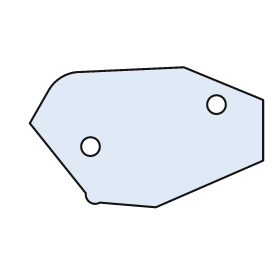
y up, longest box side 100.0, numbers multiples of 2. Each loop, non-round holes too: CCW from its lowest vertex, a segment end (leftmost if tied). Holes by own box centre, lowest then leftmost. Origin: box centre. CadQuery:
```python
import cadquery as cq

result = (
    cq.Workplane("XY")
    .moveTo(4.0, -30.0)
    .lineTo(50.0, -10.0)
    .lineTo(50.0, 16.0)
    .lineTo(16.0, 30.0)
    .lineTo(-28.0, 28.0)
    .threePointArc((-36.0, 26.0), (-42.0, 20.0))
    .lineTo(-50.0, 6.0)
    .lineTo(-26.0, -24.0)
    .threePointArc((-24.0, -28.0), (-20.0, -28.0))
    .close()
    .moveTo(-24.0, -4.0)
    .circle(4.0)
    .moveTo(30.0, 14.0)
    .circle(4.0)
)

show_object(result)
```